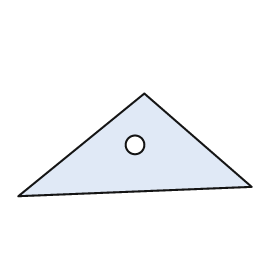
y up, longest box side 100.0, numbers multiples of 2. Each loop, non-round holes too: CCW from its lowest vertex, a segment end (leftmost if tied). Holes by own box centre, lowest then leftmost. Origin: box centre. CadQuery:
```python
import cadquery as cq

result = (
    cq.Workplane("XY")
    .moveTo(-50.0, -22.0)
    .lineTo(50.0, -18.0)
    .lineTo(4.0, 22.0)
    .close()
    .moveTo(0.0, 0.0)
    .circle(4.0)
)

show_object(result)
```